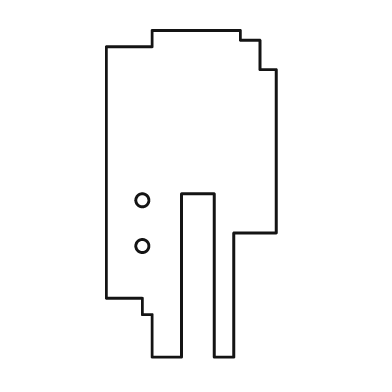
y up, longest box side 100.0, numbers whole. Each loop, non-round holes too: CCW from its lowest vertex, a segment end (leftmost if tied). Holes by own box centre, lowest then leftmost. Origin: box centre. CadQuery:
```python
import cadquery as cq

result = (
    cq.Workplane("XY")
    .moveTo(-12.0, -50.0)
    .lineTo(-3.0, -50.0)
    .lineTo(-3.0, 0.0)
    .lineTo(7.0, 0.0)
    .lineTo(7.0, -50.0)
    .lineTo(13.0, -50.0)
    .lineTo(13.0, -12.0)
    .lineTo(26.0, -12.0)
    .lineTo(26.0, 38.0)
    .lineTo(21.0, 38.0)
    .lineTo(21.0, 47.0)
    .lineTo(15.0, 47.0)
    .lineTo(15.0, 50.0)
    .lineTo(-12.0, 50.0)
    .lineTo(-12.0, 45.0)
    .lineTo(-26.0, 45.0)
    .lineTo(-26.0, -32.0)
    .lineTo(-15.0, -32.0)
    .lineTo(-15.0, -37.0)
    .lineTo(-12.0, -37.0)
    .close()
    .moveTo(-15.0, -16.0)
    .circle(2.0)
    .moveTo(-15.0, -2.0)
    .circle(2.0)
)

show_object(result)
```